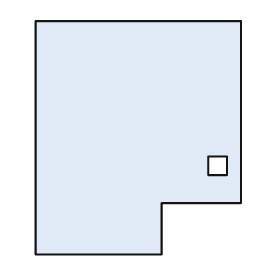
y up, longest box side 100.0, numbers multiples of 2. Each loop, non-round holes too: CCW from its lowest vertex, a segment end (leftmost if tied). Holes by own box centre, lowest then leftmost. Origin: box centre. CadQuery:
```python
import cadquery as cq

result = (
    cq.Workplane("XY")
    .moveTo(-44.0, -50.0)
    .lineTo(10.0, -50.0)
    .lineTo(10.0, -28.0)
    .lineTo(44.0, -28.0)
    .lineTo(44.0, 50.0)
    .lineTo(-44.0, 50.0)
    .close()
    .moveTo(30.0, -16.0)
    .lineTo(38.0, -16.0)
    .lineTo(38.0, -8.0)
    .lineTo(30.0, -8.0)
    .close()
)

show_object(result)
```